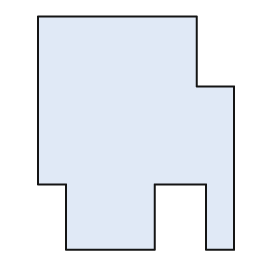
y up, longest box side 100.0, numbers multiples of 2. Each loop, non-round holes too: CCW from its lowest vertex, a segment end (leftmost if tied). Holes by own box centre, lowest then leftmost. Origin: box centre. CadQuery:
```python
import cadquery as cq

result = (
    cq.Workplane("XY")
    .moveTo(-30.0, -50.0)
    .lineTo(8.0, -50.0)
    .lineTo(8.0, -22.0)
    .lineTo(30.0, -22.0)
    .lineTo(30.0, -50.0)
    .lineTo(42.0, -50.0)
    .lineTo(42.0, 20.0)
    .lineTo(26.0, 20.0)
    .lineTo(26.0, 50.0)
    .lineTo(-42.0, 50.0)
    .lineTo(-42.0, -22.0)
    .lineTo(-30.0, -22.0)
    .close()
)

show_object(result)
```